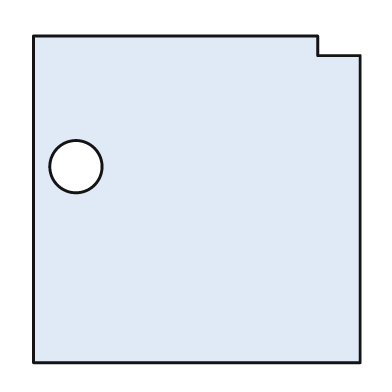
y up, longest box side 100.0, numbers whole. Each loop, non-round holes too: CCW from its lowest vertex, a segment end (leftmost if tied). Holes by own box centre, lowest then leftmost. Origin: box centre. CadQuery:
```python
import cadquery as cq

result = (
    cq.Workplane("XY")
    .moveTo(-50.0, -50.0)
    .lineTo(50.0, -50.0)
    .lineTo(50.0, 44.0)
    .lineTo(37.0, 44.0)
    .lineTo(37.0, 50.0)
    .lineTo(-50.0, 50.0)
    .close()
    .moveTo(-37.0, 10.0)
    .circle(8.0)
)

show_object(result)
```